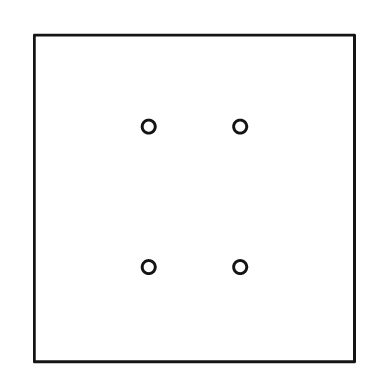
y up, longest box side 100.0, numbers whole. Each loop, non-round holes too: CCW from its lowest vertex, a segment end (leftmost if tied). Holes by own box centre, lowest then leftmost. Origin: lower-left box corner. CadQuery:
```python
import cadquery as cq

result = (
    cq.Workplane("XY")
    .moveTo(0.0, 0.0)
    .lineTo(98.0, 0.0)
    .lineTo(98.0, 100.0)
    .lineTo(0.0, 100.0)
    .close()
    .moveTo(35.0, 29.0)
    .circle(2.0)
    .moveTo(63.0, 29.0)
    .circle(2.0)
    .moveTo(35.0, 72.0)
    .circle(2.0)
    .moveTo(63.0, 72.0)
    .circle(2.0)
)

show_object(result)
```